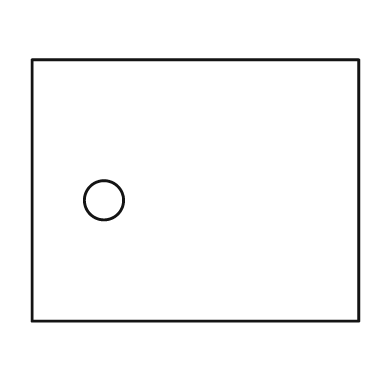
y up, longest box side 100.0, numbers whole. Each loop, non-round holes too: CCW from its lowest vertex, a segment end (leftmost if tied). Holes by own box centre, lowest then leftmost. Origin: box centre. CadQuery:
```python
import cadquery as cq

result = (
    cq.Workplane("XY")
    .moveTo(-50.0, -40.0)
    .lineTo(50.0, -40.0)
    .lineTo(50.0, 40.0)
    .lineTo(-50.0, 40.0)
    .close()
    .moveTo(-28.0, -3.0)
    .circle(6.0)
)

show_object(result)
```